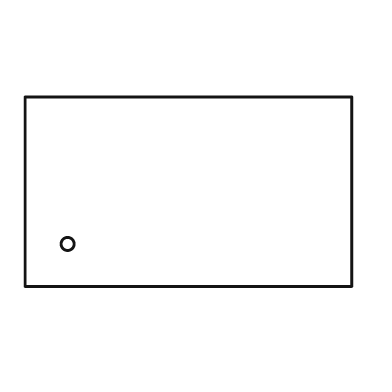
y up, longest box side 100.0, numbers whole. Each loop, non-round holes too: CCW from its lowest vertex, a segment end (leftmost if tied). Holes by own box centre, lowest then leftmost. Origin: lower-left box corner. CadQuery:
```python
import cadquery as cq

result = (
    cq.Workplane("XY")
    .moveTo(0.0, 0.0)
    .lineTo(100.0, 0.0)
    .lineTo(100.0, 58.0)
    .lineTo(0.0, 58.0)
    .close()
    .moveTo(13.0, 13.0)
    .circle(2.0)
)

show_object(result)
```